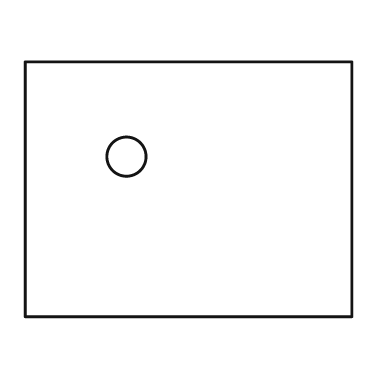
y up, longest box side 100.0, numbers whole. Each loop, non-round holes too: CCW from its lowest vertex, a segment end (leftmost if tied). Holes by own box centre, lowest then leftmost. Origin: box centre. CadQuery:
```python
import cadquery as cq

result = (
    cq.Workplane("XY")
    .moveTo(-50.0, -39.0)
    .lineTo(50.0, -39.0)
    .lineTo(50.0, 39.0)
    .lineTo(-50.0, 39.0)
    .close()
    .moveTo(-19.0, 10.0)
    .circle(6.0)
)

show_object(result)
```